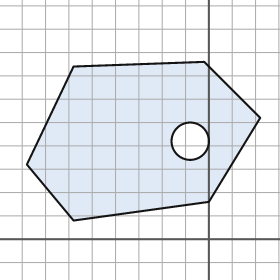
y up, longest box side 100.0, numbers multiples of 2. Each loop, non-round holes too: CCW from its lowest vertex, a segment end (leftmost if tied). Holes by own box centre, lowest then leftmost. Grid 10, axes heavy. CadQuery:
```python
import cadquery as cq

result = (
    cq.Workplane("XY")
    .moveTo(-58.0, 8.0)
    .lineTo(0.0, 16.0)
    .lineTo(22.0, 52.0)
    .lineTo(-2.0, 76.0)
    .lineTo(-58.0, 74.0)
    .lineTo(-78.0, 32.0)
    .close()
    .moveTo(-8.0, 42.0)
    .circle(8.0)
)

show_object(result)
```